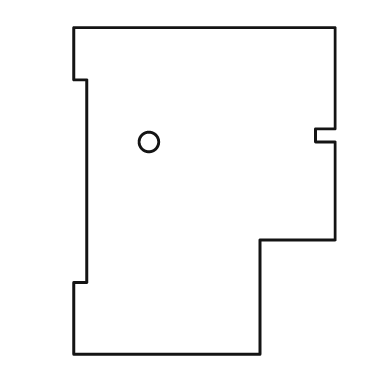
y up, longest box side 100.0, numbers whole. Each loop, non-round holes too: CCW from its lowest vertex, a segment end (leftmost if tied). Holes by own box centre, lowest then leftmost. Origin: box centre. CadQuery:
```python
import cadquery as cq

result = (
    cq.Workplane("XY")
    .moveTo(-40.0, -50.0)
    .lineTo(17.0, -50.0)
    .lineTo(17.0, -15.0)
    .lineTo(40.0, -15.0)
    .lineTo(40.0, 15.0)
    .lineTo(34.0, 15.0)
    .lineTo(34.0, 19.0)
    .lineTo(40.0, 19.0)
    .lineTo(40.0, 50.0)
    .lineTo(-40.0, 50.0)
    .lineTo(-40.0, 34.0)
    .lineTo(-36.0, 34.0)
    .lineTo(-36.0, -28.0)
    .lineTo(-40.0, -28.0)
    .close()
    .moveTo(-17.0, 15.0)
    .circle(3.0)
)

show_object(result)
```